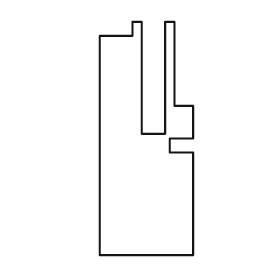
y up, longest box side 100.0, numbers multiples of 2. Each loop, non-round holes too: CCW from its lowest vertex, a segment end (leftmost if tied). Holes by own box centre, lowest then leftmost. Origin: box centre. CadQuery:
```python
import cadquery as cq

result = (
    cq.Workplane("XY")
    .moveTo(-20.0, -50.0)
    .lineTo(20.0, -50.0)
    .lineTo(20.0, -6.0)
    .lineTo(10.0, -6.0)
    .lineTo(10.0, 0.0)
    .lineTo(20.0, 0.0)
    .lineTo(20.0, 14.0)
    .lineTo(12.0, 14.0)
    .lineTo(12.0, 50.0)
    .lineTo(8.0, 50.0)
    .lineTo(8.0, 2.0)
    .lineTo(-2.0, 2.0)
    .lineTo(-2.0, 50.0)
    .lineTo(-6.0, 50.0)
    .lineTo(-6.0, 44.0)
    .lineTo(-20.0, 44.0)
    .close()
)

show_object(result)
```